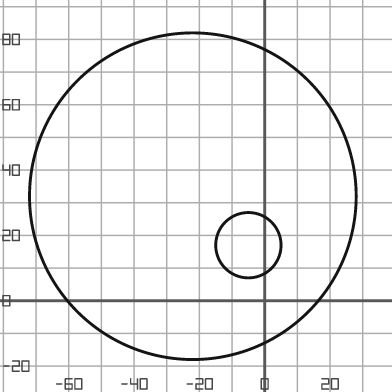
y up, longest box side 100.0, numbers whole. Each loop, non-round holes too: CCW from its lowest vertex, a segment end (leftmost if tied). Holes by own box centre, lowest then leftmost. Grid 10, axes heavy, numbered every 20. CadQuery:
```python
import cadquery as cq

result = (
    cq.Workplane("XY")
    .moveTo(-22.0, 32.0)
    .circle(50.0)
    .moveTo(-5.0, 17.0)
    .circle(10.0)
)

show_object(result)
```